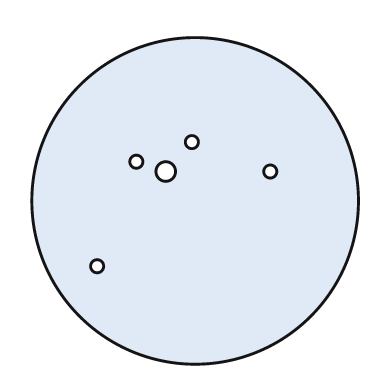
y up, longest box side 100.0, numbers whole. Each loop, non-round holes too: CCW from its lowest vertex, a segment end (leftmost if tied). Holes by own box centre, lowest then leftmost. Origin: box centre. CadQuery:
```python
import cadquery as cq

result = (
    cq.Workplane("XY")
    .moveTo(0.0, 0.0)
    .circle(50.0)
    .moveTo(-30.0, -20.0)
    .circle(2.0)
    .moveTo(-9.0, 9.0)
    .circle(3.0)
    .moveTo(23.0, 9.0)
    .circle(2.0)
    .moveTo(-18.0, 12.0)
    .circle(2.0)
    .moveTo(-1.0, 18.0)
    .circle(2.0)
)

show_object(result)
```